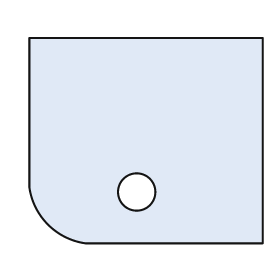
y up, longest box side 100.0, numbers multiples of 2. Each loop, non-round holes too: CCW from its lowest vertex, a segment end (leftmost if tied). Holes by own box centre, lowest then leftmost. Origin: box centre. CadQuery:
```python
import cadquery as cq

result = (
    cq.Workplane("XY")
    .moveTo(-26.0, -44.0)
    .lineTo(50.0, -44.0)
    .lineTo(50.0, 44.0)
    .lineTo(-50.0, 44.0)
    .lineTo(-50.0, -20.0)
    .threePointArc((-42.0, -36.0), (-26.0, -44.0))
    .close()
    .moveTo(-4.0, -22.0)
    .circle(8.0)
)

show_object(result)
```